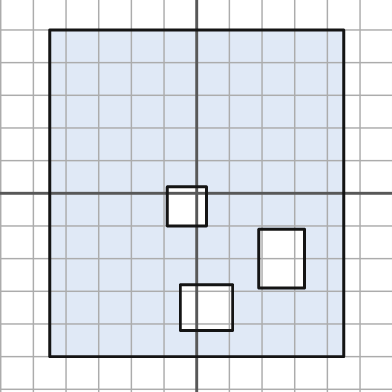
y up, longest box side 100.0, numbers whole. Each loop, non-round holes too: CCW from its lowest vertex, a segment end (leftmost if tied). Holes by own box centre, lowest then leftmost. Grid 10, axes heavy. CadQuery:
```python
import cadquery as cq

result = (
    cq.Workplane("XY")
    .moveTo(-45.0, -50.0)
    .lineTo(45.0, -50.0)
    .lineTo(45.0, 50.0)
    .lineTo(-45.0, 50.0)
    .close()
    .moveTo(-5.0, -42.0)
    .lineTo(11.0, -42.0)
    .lineTo(11.0, -28.0)
    .lineTo(-5.0, -28.0)
    .close()
    .moveTo(19.0, -29.0)
    .lineTo(33.0, -29.0)
    .lineTo(33.0, -11.0)
    .lineTo(19.0, -11.0)
    .close()
    .moveTo(-9.0, -10.0)
    .lineTo(3.0, -10.0)
    .lineTo(3.0, 2.0)
    .lineTo(-9.0, 2.0)
    .close()
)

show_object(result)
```